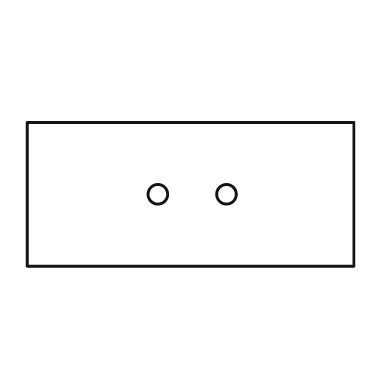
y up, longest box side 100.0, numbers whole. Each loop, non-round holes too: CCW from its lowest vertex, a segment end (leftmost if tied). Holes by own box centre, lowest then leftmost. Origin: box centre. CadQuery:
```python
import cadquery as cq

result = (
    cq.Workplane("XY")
    .moveTo(-50.0, -22.0)
    .lineTo(50.0, -22.0)
    .lineTo(50.0, 22.0)
    .lineTo(-50.0, 22.0)
    .close()
    .moveTo(-10.0, 0.0)
    .circle(3.0)
    .moveTo(11.0, 0.0)
    .circle(3.0)
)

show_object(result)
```